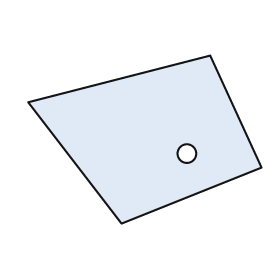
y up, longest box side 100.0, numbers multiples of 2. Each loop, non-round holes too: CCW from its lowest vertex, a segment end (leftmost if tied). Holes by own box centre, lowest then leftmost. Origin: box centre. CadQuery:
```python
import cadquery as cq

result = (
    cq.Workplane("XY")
    .moveTo(-10.0, -36.0)
    .lineTo(50.0, -12.0)
    .lineTo(28.0, 36.0)
    .lineTo(-50.0, 16.0)
    .close()
    .moveTo(18.0, -6.0)
    .circle(4.0)
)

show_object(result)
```